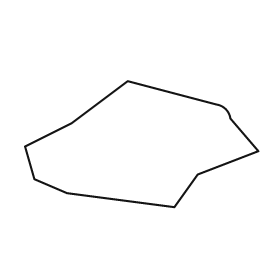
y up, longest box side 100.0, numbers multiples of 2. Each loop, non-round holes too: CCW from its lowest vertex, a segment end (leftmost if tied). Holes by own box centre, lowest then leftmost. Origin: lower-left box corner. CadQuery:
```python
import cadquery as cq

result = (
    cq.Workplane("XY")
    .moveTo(64.0, 0.0)
    .lineTo(74.0, 14.0)
    .lineTo(100.0, 24.0)
    .lineTo(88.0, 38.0)
    .threePointArc((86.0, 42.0), (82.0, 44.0))
    .lineTo(44.0, 54.0)
    .lineTo(20.0, 36.0)
    .lineTo(0.0, 26.0)
    .lineTo(4.0, 12.0)
    .lineTo(18.0, 6.0)
    .close()
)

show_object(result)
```